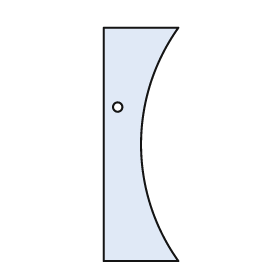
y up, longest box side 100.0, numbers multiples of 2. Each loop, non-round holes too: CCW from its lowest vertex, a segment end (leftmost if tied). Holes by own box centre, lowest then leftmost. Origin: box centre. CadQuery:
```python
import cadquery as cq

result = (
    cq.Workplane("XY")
    .moveTo(-16.0, -50.0)
    .lineTo(16.0, -50.0)
    .threePointArc((0.0, 0.0), (16.0, 50.0))
    .lineTo(-16.0, 50.0)
    .close()
    .moveTo(-10.0, 16.0)
    .circle(2.0)
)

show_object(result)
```